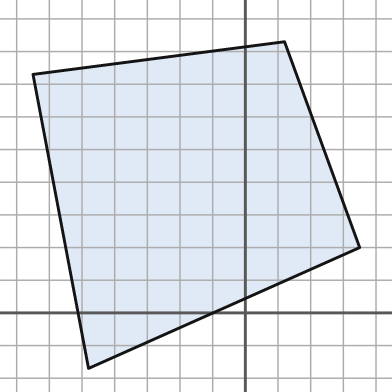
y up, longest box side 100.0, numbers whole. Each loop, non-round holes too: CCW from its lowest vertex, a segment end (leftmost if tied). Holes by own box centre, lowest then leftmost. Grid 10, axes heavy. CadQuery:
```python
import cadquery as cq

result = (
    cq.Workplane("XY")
    .moveTo(-48.0, -17.0)
    .lineTo(35.0, 20.0)
    .lineTo(12.0, 83.0)
    .lineTo(-65.0, 73.0)
    .close()
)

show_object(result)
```